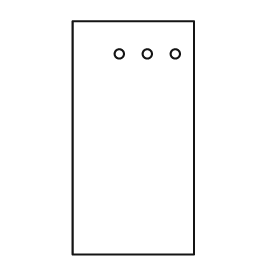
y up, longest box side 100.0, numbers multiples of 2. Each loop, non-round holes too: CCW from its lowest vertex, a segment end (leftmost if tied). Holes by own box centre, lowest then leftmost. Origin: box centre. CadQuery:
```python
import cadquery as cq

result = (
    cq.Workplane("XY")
    .moveTo(-26.0, -50.0)
    .lineTo(26.0, -50.0)
    .lineTo(26.0, 50.0)
    .lineTo(-26.0, 50.0)
    .close()
    .moveTo(-6.0, 36.0)
    .circle(2.0)
    .moveTo(6.0, 36.0)
    .circle(2.0)
    .moveTo(18.0, 36.0)
    .circle(2.0)
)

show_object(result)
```